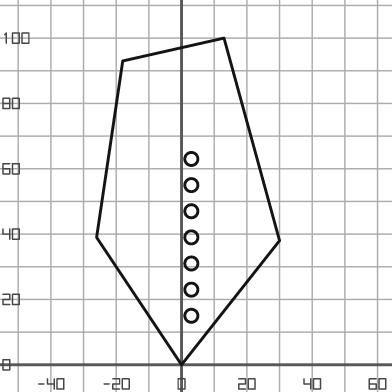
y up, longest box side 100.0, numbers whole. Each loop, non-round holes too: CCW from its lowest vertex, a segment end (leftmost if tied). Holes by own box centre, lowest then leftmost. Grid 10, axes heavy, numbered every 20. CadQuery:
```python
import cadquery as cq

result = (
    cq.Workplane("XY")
    .moveTo(0.0, 0.0)
    .lineTo(30.0, 38.0)
    .lineTo(13.0, 100.0)
    .lineTo(-18.0, 93.0)
    .lineTo(-26.0, 39.0)
    .close()
    .moveTo(3.0, 15.0)
    .circle(2.0)
    .moveTo(3.0, 23.0)
    .circle(2.0)
    .moveTo(3.0, 31.0)
    .circle(2.0)
    .moveTo(3.0, 39.0)
    .circle(2.0)
    .moveTo(3.0, 47.0)
    .circle(2.0)
    .moveTo(3.0, 55.0)
    .circle(2.0)
    .moveTo(3.0, 63.0)
    .circle(2.0)
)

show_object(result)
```